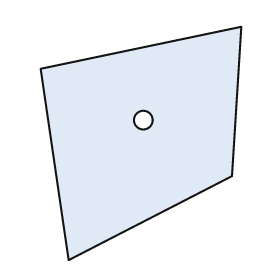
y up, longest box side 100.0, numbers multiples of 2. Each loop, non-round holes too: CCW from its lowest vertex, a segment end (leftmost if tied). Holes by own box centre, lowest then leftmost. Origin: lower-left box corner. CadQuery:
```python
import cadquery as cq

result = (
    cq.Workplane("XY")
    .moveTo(12.0, 0.0)
    .lineTo(82.0, 36.0)
    .lineTo(86.0, 100.0)
    .lineTo(0.0, 82.0)
    .close()
    .moveTo(44.0, 60.0)
    .circle(4.0)
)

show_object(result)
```